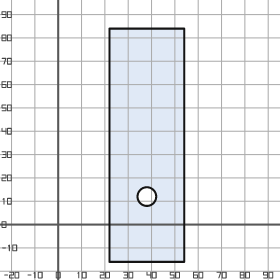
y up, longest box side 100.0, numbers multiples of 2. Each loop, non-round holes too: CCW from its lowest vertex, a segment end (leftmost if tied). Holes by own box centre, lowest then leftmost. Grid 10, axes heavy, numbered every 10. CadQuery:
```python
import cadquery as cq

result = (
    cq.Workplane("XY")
    .moveTo(22.0, -16.0)
    .lineTo(54.0, -16.0)
    .lineTo(54.0, 84.0)
    .lineTo(22.0, 84.0)
    .close()
    .moveTo(38.0, 12.0)
    .circle(4.0)
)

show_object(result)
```